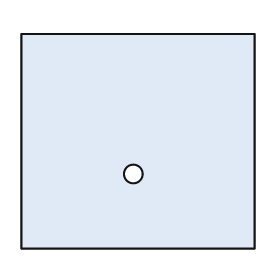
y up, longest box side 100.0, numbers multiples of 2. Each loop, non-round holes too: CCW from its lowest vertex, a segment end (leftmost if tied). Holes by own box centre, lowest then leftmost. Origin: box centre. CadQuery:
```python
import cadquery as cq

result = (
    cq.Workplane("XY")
    .moveTo(-50.0, -46.0)
    .lineTo(50.0, -46.0)
    .lineTo(50.0, 46.0)
    .lineTo(-50.0, 46.0)
    .close()
    .moveTo(-2.0, -14.0)
    .circle(4.0)
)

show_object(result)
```